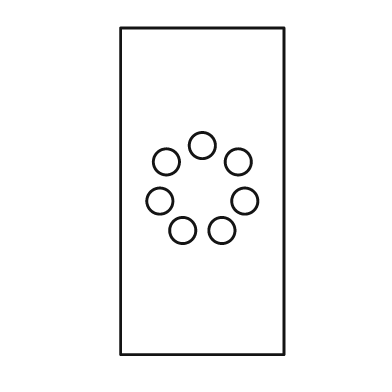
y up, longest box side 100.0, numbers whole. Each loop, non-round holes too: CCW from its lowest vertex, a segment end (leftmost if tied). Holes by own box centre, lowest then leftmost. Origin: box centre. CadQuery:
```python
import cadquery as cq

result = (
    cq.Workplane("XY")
    .moveTo(-25.0, -50.0)
    .lineTo(25.0, -50.0)
    .lineTo(25.0, 50.0)
    .lineTo(-25.0, 50.0)
    .close()
    .moveTo(-6.0, -12.0)
    .circle(4.0)
    .moveTo(6.0, -12.0)
    .circle(4.0)
    .moveTo(-13.0, -3.0)
    .circle(4.0)
    .moveTo(13.0, -3.0)
    .circle(4.0)
    .moveTo(-11.0, 9.0)
    .circle(4.0)
    .moveTo(11.0, 9.0)
    .circle(4.0)
    .moveTo(0.0, 14.0)
    .circle(4.0)
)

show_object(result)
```